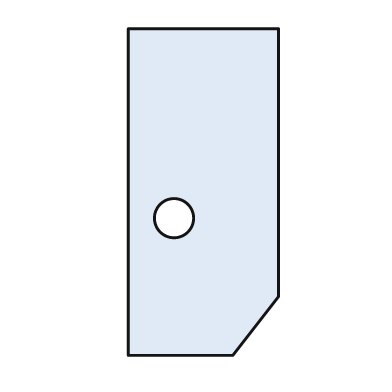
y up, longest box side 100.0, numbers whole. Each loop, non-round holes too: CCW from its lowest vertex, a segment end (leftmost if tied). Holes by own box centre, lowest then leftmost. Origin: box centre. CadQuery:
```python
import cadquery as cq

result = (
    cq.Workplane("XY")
    .moveTo(-23.0, -50.0)
    .lineTo(9.0, -50.0)
    .lineTo(23.0, -32.0)
    .lineTo(23.0, 50.0)
    .lineTo(-23.0, 50.0)
    .close()
    .moveTo(-9.0, -8.0)
    .circle(6.0)
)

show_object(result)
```